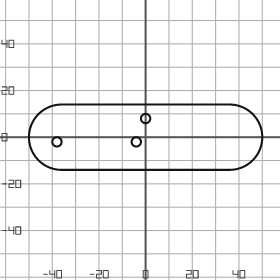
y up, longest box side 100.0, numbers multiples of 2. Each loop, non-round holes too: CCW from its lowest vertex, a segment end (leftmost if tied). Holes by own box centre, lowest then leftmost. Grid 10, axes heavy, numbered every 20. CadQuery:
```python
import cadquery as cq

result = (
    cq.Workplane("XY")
    .moveTo(-36.0, -14.0)
    .lineTo(36.0, -14.0)
    .threePointArc((50.0, 0.0), (36.0, 14.0))
    .lineTo(-36.0, 14.0)
    .threePointArc((-50.0, 0.0), (-36.0, -14.0))
    .close()
    .moveTo(-38.0, -2.0)
    .circle(2.0)
    .moveTo(-4.0, -2.0)
    .circle(2.0)
    .moveTo(0.0, 8.0)
    .circle(2.0)
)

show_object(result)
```